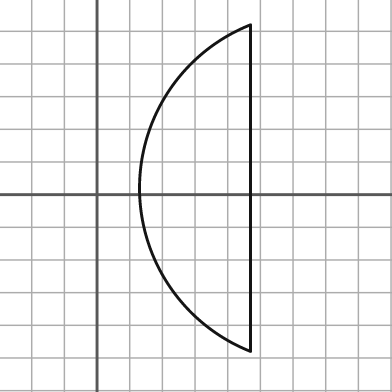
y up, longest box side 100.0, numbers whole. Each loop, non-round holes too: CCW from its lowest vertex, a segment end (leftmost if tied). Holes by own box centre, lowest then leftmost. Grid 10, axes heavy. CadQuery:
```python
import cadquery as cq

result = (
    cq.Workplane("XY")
    .moveTo(47.0, -48.0)
    .lineTo(47.0, 52.0)
    .threePointArc((13.0, 2.0), (47.0, -48.0))
    .close()
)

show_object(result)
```